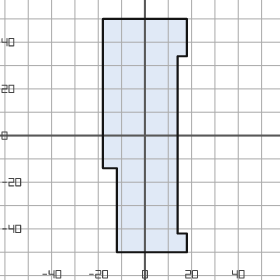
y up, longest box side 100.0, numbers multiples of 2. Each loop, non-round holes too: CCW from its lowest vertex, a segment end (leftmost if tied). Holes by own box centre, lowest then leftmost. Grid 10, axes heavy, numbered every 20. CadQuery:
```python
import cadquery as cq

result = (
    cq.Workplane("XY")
    .moveTo(-12.0, -50.0)
    .lineTo(18.0, -50.0)
    .lineTo(18.0, -42.0)
    .lineTo(14.0, -42.0)
    .lineTo(14.0, 34.0)
    .lineTo(18.0, 34.0)
    .lineTo(18.0, 50.0)
    .lineTo(-18.0, 50.0)
    .lineTo(-18.0, -14.0)
    .lineTo(-12.0, -14.0)
    .close()
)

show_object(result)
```